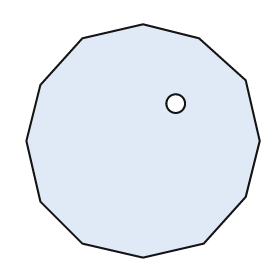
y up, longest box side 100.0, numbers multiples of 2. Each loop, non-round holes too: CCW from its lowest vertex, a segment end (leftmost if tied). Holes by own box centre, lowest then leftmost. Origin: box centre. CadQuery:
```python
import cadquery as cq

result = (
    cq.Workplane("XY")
    .moveTo(0.0, -50.0)
    .lineTo(26.0, -44.0)
    .lineTo(44.0, -24.0)
    .lineTo(50.0, 0.0)
    .lineTo(44.0, 26.0)
    .lineTo(24.0, 44.0)
    .lineTo(0.0, 50.0)
    .lineTo(-26.0, 44.0)
    .lineTo(-44.0, 24.0)
    .lineTo(-50.0, 0.0)
    .lineTo(-44.0, -26.0)
    .lineTo(-26.0, -44.0)
    .close()
    .moveTo(14.0, 16.0)
    .circle(4.0)
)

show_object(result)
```